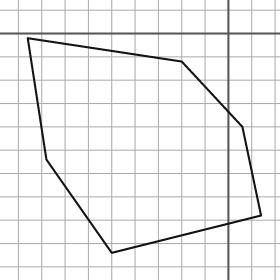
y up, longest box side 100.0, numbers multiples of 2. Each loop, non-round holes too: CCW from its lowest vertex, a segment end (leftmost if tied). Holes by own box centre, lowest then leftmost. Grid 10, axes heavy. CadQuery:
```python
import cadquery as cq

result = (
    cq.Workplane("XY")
    .moveTo(-50.0, -94.0)
    .lineTo(14.0, -78.0)
    .lineTo(6.0, -40.0)
    .lineTo(-20.0, -12.0)
    .lineTo(-86.0, -2.0)
    .lineTo(-78.0, -54.0)
    .close()
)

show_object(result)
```